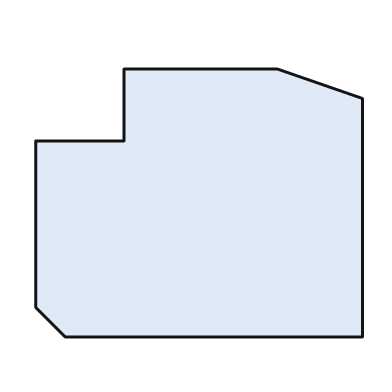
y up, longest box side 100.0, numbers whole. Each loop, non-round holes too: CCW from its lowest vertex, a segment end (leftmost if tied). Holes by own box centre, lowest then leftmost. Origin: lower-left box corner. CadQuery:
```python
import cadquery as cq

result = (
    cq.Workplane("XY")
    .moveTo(9.0, 0.0)
    .lineTo(100.0, 0.0)
    .lineTo(100.0, 73.0)
    .lineTo(74.0, 82.0)
    .lineTo(27.0, 82.0)
    .lineTo(27.0, 60.0)
    .lineTo(0.0, 60.0)
    .lineTo(0.0, 9.0)
    .close()
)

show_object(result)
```